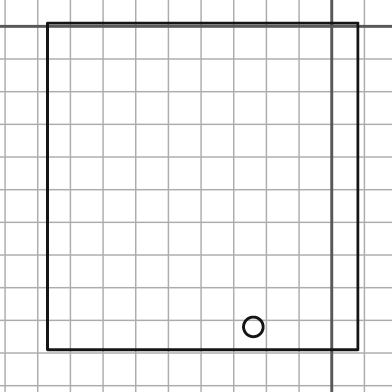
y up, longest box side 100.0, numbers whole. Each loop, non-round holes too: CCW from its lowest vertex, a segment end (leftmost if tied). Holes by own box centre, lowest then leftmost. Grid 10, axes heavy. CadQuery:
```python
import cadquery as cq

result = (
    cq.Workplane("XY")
    .moveTo(-87.0, -99.0)
    .lineTo(8.0, -99.0)
    .lineTo(8.0, 1.0)
    .lineTo(-87.0, 1.0)
    .close()
    .moveTo(-24.0, -92.0)
    .circle(3.0)
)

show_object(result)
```